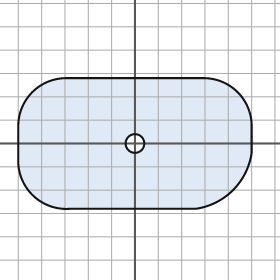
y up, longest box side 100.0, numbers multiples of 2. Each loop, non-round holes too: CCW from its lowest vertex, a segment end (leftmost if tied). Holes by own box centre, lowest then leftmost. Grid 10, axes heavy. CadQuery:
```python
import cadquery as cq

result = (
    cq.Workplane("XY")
    .moveTo(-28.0, -28.0)
    .lineTo(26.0, -28.0)
    .threePointArc((42.0, -20.0), (50.0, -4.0))
    .lineTo(50.0, 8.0)
    .threePointArc((44.0, 22.0), (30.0, 28.0))
    .lineTo(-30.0, 28.0)
    .threePointArc((-44.0, 22.0), (-50.0, 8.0))
    .lineTo(-50.0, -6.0)
    .threePointArc((-44.0, -22.0), (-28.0, -28.0))
    .close()
    .moveTo(0.0, 0.0)
    .circle(4.0)
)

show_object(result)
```